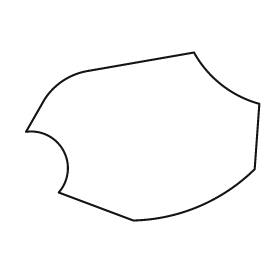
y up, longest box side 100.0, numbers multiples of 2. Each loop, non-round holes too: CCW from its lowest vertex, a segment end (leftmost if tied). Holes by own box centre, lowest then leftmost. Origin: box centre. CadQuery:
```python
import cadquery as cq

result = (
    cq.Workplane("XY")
    .moveTo(-4.0, -36.0)
    .threePointArc((24.0, -30.0), (48.0, -14.0))
    .lineTo(50.0, 14.0)
    .threePointArc((34.0, 22.0), (22.0, 36.0))
    .lineTo(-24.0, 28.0)
    .threePointArc((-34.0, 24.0), (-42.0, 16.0))
    .lineTo(-50.0, 2.0)
    .threePointArc((-34.0, -6.0), (-36.0, -24.0))
    .close()
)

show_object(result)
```